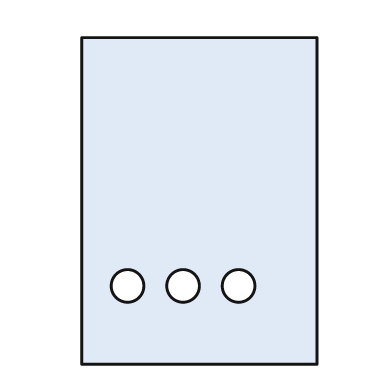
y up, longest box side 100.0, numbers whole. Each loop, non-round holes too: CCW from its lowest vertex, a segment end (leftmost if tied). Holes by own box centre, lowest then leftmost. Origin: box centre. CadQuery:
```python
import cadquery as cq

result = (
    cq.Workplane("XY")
    .moveTo(-36.0, -50.0)
    .lineTo(36.0, -50.0)
    .lineTo(36.0, 50.0)
    .lineTo(-36.0, 50.0)
    .close()
    .moveTo(-22.0, -26.0)
    .circle(5.0)
    .moveTo(-5.0, -26.0)
    .circle(5.0)
    .moveTo(12.0, -26.0)
    .circle(5.0)
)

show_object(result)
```